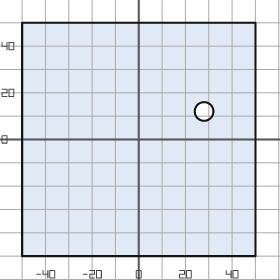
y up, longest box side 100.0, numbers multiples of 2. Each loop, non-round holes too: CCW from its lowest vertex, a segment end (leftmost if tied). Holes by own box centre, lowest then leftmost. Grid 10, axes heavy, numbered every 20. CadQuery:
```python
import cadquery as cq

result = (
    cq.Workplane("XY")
    .moveTo(-50.0, -50.0)
    .lineTo(50.0, -50.0)
    .lineTo(50.0, 50.0)
    .lineTo(-50.0, 50.0)
    .close()
    .moveTo(28.0, 12.0)
    .circle(4.0)
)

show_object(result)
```